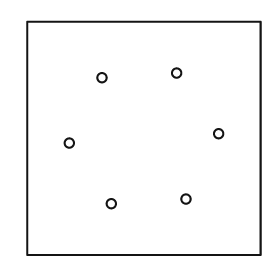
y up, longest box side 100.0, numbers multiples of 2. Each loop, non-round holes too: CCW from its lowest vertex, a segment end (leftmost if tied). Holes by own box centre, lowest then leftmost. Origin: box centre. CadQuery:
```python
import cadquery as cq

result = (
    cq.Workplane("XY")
    .moveTo(-50.0, -50.0)
    .lineTo(50.0, -50.0)
    .lineTo(50.0, 50.0)
    .lineTo(-50.0, 50.0)
    .close()
    .moveTo(-14.0, -28.0)
    .circle(2.0)
    .moveTo(18.0, -26.0)
    .circle(2.0)
    .moveTo(-32.0, -2.0)
    .circle(2.0)
    .moveTo(32.0, 2.0)
    .circle(2.0)
    .moveTo(-18.0, 26.0)
    .circle(2.0)
    .moveTo(14.0, 28.0)
    .circle(2.0)
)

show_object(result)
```